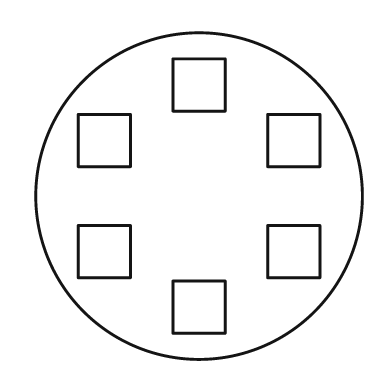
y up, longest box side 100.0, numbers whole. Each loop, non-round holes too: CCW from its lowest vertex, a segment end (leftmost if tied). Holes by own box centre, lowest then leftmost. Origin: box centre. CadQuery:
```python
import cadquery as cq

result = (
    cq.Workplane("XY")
    .moveTo(0.0, 0.0)
    .circle(50.0)
    .moveTo(-8.0, -42.0)
    .lineTo(8.0, -42.0)
    .lineTo(8.0, -26.0)
    .lineTo(-8.0, -26.0)
    .close()
    .moveTo(-37.0, -25.0)
    .lineTo(-21.0, -25.0)
    .lineTo(-21.0, -9.0)
    .lineTo(-37.0, -9.0)
    .close()
    .moveTo(21.0, -25.0)
    .lineTo(37.0, -25.0)
    .lineTo(37.0, -9.0)
    .lineTo(21.0, -9.0)
    .close()
    .moveTo(-37.0, 9.0)
    .lineTo(-21.0, 9.0)
    .lineTo(-21.0, 25.0)
    .lineTo(-37.0, 25.0)
    .close()
    .moveTo(21.0, 9.0)
    .lineTo(37.0, 9.0)
    .lineTo(37.0, 25.0)
    .lineTo(21.0, 25.0)
    .close()
    .moveTo(-8.0, 26.0)
    .lineTo(8.0, 26.0)
    .lineTo(8.0, 42.0)
    .lineTo(-8.0, 42.0)
    .close()
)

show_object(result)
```